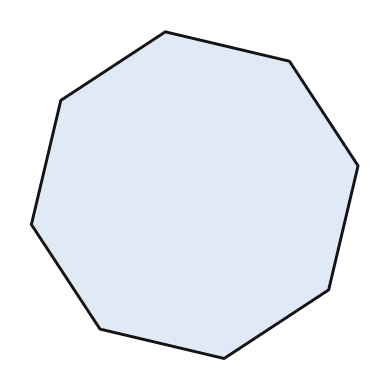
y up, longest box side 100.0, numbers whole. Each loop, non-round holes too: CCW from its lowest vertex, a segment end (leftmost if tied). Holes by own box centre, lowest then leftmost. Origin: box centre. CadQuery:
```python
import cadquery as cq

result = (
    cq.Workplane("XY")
    .moveTo(9.0, -50.0)
    .lineTo(41.0, -29.0)
    .lineTo(50.0, 9.0)
    .lineTo(29.0, 41.0)
    .lineTo(-9.0, 50.0)
    .lineTo(-41.0, 29.0)
    .lineTo(-50.0, -9.0)
    .lineTo(-29.0, -41.0)
    .close()
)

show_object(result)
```